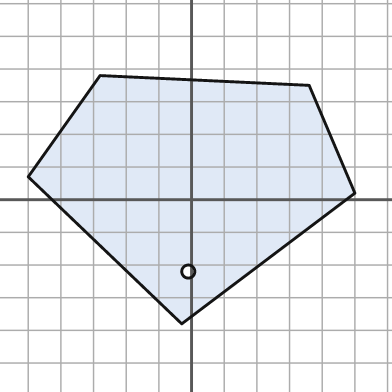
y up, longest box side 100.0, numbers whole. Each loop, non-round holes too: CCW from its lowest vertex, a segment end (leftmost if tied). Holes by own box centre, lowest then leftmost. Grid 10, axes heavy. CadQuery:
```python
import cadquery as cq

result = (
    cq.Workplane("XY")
    .moveTo(-3.0, -38.0)
    .lineTo(50.0, 2.0)
    .lineTo(36.0, 35.0)
    .lineTo(-28.0, 38.0)
    .lineTo(-50.0, 7.0)
    .close()
    .moveTo(-1.0, -22.0)
    .circle(2.0)
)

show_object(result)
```